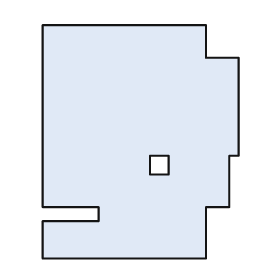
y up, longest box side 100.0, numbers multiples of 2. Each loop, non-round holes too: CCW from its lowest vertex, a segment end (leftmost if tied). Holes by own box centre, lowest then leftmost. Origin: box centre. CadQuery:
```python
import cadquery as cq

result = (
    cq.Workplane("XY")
    .moveTo(-42.0, -50.0)
    .lineTo(28.0, -50.0)
    .lineTo(28.0, -28.0)
    .lineTo(38.0, -28.0)
    .lineTo(38.0, -6.0)
    .lineTo(42.0, -6.0)
    .lineTo(42.0, 36.0)
    .lineTo(28.0, 36.0)
    .lineTo(28.0, 50.0)
    .lineTo(-42.0, 50.0)
    .lineTo(-42.0, -28.0)
    .lineTo(-18.0, -28.0)
    .lineTo(-18.0, -34.0)
    .lineTo(-42.0, -34.0)
    .close()
    .moveTo(4.0, -14.0)
    .lineTo(12.0, -14.0)
    .lineTo(12.0, -6.0)
    .lineTo(4.0, -6.0)
    .close()
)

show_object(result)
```